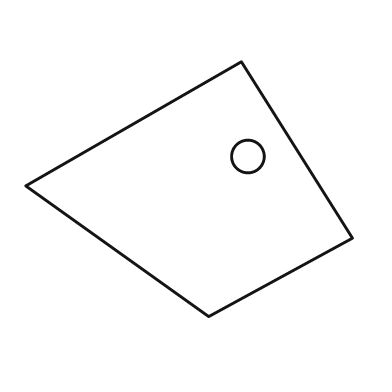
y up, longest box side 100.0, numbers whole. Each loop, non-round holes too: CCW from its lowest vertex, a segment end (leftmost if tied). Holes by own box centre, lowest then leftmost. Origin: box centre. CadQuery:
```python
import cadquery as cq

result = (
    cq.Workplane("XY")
    .moveTo(6.0, -39.0)
    .lineTo(50.0, -15.0)
    .lineTo(16.0, 39.0)
    .lineTo(-50.0, 1.0)
    .close()
    .moveTo(18.0, 10.0)
    .circle(5.0)
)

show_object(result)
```